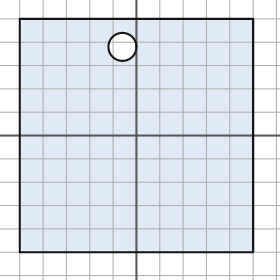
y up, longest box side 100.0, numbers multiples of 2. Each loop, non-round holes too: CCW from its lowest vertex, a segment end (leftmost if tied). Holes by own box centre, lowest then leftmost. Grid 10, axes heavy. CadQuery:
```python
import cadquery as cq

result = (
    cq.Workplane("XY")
    .moveTo(-50.0, -50.0)
    .lineTo(50.0, -50.0)
    .lineTo(50.0, 50.0)
    .lineTo(-50.0, 50.0)
    .close()
    .moveTo(-6.0, 38.0)
    .circle(6.0)
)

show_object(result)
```